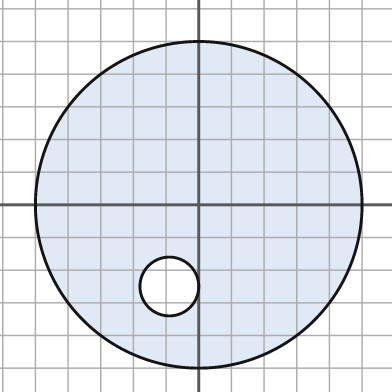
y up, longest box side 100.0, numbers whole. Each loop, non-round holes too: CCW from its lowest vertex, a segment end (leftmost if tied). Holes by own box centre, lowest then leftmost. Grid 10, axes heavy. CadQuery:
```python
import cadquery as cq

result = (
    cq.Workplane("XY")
    .moveTo(0.0, 0.0)
    .circle(50.0)
    .moveTo(-9.0, -25.0)
    .circle(9.0)
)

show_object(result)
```